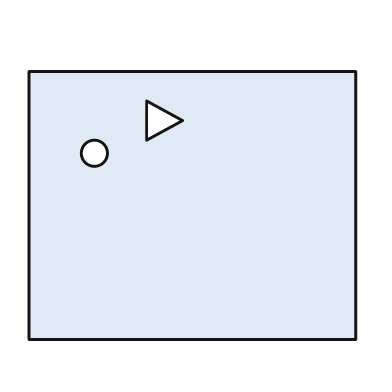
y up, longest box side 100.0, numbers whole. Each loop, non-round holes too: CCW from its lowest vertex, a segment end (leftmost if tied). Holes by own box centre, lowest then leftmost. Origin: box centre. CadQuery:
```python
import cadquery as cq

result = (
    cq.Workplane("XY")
    .moveTo(-50.0, -41.0)
    .lineTo(50.0, -41.0)
    .lineTo(50.0, 41.0)
    .lineTo(-50.0, 41.0)
    .close()
    .moveTo(-30.0, 16.0)
    .circle(4.0)
    .moveTo(-14.0, 20.0)
    .lineTo(-3.0, 26.0)
    .lineTo(-14.0, 32.0)
    .close()
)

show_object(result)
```